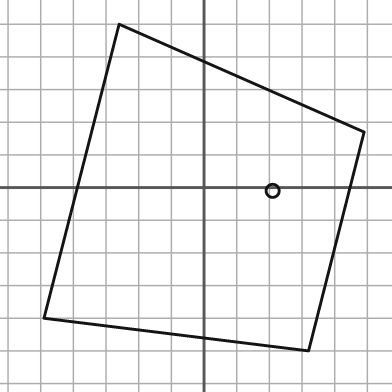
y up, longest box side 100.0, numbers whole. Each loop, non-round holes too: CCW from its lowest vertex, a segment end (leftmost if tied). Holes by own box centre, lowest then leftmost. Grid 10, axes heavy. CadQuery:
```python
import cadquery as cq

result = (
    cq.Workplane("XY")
    .moveTo(32.0, -50.0)
    .lineTo(49.0, 17.0)
    .lineTo(-26.0, 50.0)
    .lineTo(-49.0, -40.0)
    .close()
    .moveTo(21.0, -1.0)
    .circle(2.0)
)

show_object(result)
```